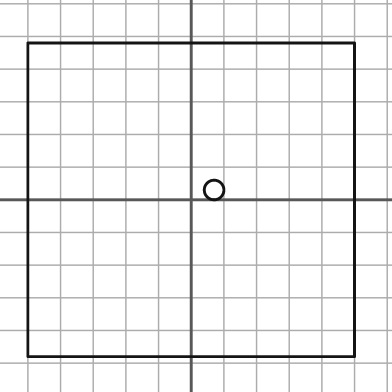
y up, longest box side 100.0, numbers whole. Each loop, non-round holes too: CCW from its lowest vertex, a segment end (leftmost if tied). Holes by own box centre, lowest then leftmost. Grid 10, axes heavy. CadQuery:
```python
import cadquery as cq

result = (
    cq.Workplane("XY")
    .moveTo(-50.0, -48.0)
    .lineTo(50.0, -48.0)
    .lineTo(50.0, 48.0)
    .lineTo(-50.0, 48.0)
    .close()
    .moveTo(7.0, 3.0)
    .circle(3.0)
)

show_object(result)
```